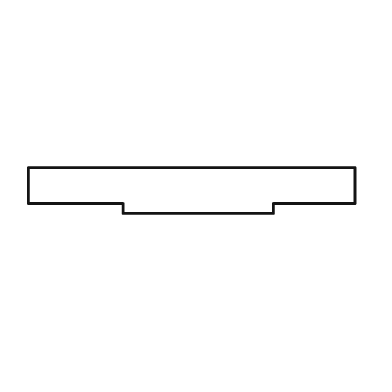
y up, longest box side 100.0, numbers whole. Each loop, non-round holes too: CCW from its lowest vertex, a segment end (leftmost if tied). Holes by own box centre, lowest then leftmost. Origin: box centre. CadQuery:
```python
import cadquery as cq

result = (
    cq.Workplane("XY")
    .moveTo(-21.0, -7.0)
    .lineTo(25.0, -7.0)
    .lineTo(25.0, -4.0)
    .lineTo(50.0, -4.0)
    .lineTo(50.0, 7.0)
    .lineTo(-50.0, 7.0)
    .lineTo(-50.0, -4.0)
    .lineTo(-21.0, -4.0)
    .close()
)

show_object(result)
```